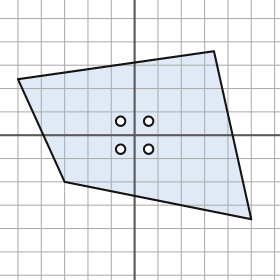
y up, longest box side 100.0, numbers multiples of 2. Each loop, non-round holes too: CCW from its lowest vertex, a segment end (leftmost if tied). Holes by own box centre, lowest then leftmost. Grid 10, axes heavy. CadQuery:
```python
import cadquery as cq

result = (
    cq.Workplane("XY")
    .moveTo(50.0, -36.0)
    .lineTo(34.0, 36.0)
    .lineTo(-50.0, 24.0)
    .lineTo(-30.0, -20.0)
    .close()
    .moveTo(-6.0, -6.0)
    .circle(2.0)
    .moveTo(6.0, -6.0)
    .circle(2.0)
    .moveTo(-6.0, 6.0)
    .circle(2.0)
    .moveTo(6.0, 6.0)
    .circle(2.0)
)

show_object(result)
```